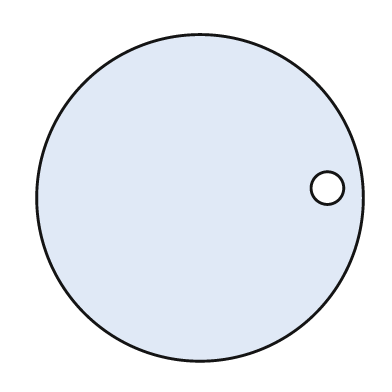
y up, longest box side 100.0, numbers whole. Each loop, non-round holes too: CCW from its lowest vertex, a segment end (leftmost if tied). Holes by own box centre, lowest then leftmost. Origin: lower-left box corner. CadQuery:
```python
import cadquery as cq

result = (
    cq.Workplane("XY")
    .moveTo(50.0, 50.0)
    .circle(50.0)
    .moveTo(89.0, 53.0)
    .circle(5.0)
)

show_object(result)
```